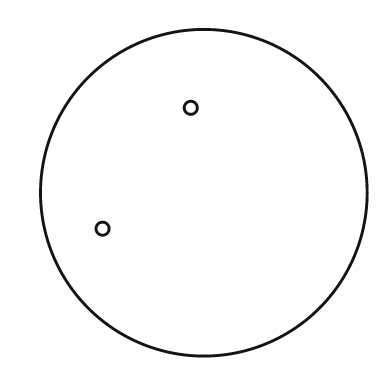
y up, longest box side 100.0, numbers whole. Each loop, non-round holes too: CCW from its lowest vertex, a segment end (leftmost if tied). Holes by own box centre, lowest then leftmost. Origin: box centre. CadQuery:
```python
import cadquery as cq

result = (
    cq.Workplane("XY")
    .moveTo(0.0, 0.0)
    .circle(50.0)
    .moveTo(-31.0, -11.0)
    .circle(2.0)
    .moveTo(-4.0, 26.0)
    .circle(2.0)
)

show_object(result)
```